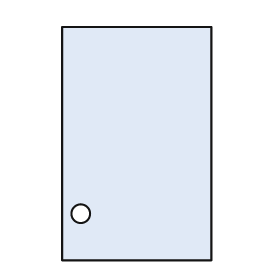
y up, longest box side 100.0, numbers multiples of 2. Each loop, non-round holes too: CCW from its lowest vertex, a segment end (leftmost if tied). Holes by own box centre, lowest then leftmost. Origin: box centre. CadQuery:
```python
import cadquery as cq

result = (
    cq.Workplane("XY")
    .moveTo(-32.0, -50.0)
    .lineTo(32.0, -50.0)
    .lineTo(32.0, 50.0)
    .lineTo(-32.0, 50.0)
    .close()
    .moveTo(-24.0, -30.0)
    .circle(4.0)
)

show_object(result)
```